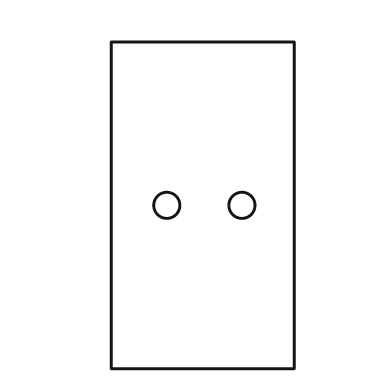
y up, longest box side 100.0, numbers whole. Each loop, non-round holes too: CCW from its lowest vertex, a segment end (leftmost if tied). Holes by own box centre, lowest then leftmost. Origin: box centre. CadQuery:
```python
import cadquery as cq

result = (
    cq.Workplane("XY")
    .moveTo(-28.0, -50.0)
    .lineTo(28.0, -50.0)
    .lineTo(28.0, 50.0)
    .lineTo(-28.0, 50.0)
    .close()
    .moveTo(-11.0, 0.0)
    .circle(4.0)
    .moveTo(12.0, 0.0)
    .circle(4.0)
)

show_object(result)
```